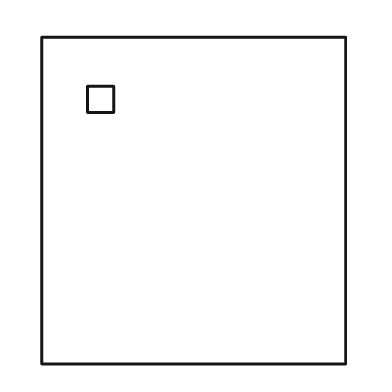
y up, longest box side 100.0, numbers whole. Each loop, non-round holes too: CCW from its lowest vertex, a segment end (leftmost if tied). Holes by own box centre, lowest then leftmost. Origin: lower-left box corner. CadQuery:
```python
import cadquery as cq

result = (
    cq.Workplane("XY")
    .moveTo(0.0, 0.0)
    .lineTo(93.0, 0.0)
    .lineTo(93.0, 100.0)
    .lineTo(0.0, 100.0)
    .close()
    .moveTo(14.0, 77.0)
    .lineTo(22.0, 77.0)
    .lineTo(22.0, 85.0)
    .lineTo(14.0, 85.0)
    .close()
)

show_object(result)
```